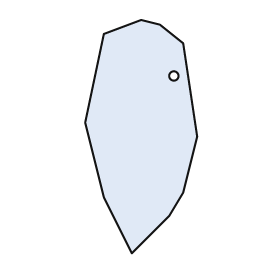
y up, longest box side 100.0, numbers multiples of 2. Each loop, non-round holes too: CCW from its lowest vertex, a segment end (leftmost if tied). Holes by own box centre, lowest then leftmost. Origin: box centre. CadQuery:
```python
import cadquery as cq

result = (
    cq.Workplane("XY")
    .moveTo(-4.0, -50.0)
    .lineTo(12.0, -34.0)
    .lineTo(18.0, -24.0)
    .lineTo(24.0, 0.0)
    .lineTo(18.0, 40.0)
    .lineTo(8.0, 48.0)
    .lineTo(0.0, 50.0)
    .lineTo(-16.0, 44.0)
    .lineTo(-24.0, 6.0)
    .lineTo(-16.0, -26.0)
    .close()
    .moveTo(14.0, 26.0)
    .circle(2.0)
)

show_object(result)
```